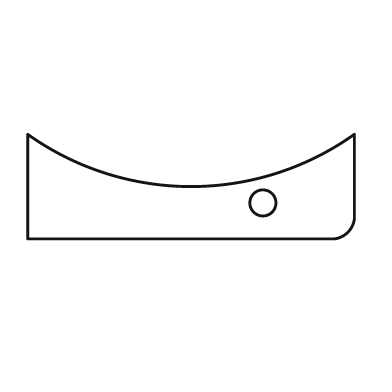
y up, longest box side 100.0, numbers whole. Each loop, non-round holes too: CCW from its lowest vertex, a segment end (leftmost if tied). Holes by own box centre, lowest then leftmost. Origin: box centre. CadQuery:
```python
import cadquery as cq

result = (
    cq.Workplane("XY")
    .moveTo(-50.0, -16.0)
    .lineTo(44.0, -16.0)
    .threePointArc((48.0, -14.0), (50.0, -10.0))
    .lineTo(50.0, 16.0)
    .threePointArc((0.0, 0.0), (-50.0, 16.0))
    .close()
    .moveTo(22.0, -5.0)
    .circle(4.0)
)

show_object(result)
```